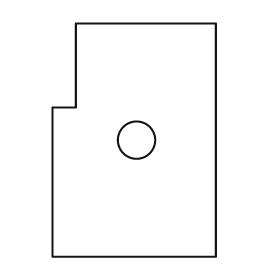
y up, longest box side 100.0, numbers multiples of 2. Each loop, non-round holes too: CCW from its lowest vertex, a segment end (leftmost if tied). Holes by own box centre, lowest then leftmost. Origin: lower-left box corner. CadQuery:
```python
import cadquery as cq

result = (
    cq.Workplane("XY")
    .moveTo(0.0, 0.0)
    .lineTo(70.0, 0.0)
    .lineTo(70.0, 100.0)
    .lineTo(10.0, 100.0)
    .lineTo(10.0, 64.0)
    .lineTo(0.0, 64.0)
    .close()
    .moveTo(36.0, 50.0)
    .circle(8.0)
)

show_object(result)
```